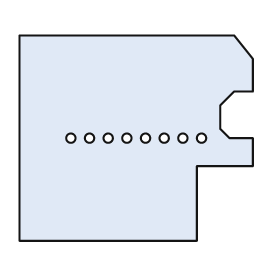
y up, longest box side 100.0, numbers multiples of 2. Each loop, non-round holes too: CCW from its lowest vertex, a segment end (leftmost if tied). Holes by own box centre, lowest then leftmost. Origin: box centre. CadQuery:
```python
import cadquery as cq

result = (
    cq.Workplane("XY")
    .moveTo(-50.0, -44.0)
    .lineTo(26.0, -44.0)
    .lineTo(26.0, -12.0)
    .lineTo(50.0, -12.0)
    .lineTo(50.0, 0.0)
    .lineTo(40.0, 0.0)
    .lineTo(36.0, 4.0)
    .lineTo(36.0, 14.0)
    .lineTo(42.0, 20.0)
    .lineTo(50.0, 20.0)
    .lineTo(50.0, 34.0)
    .lineTo(42.0, 44.0)
    .lineTo(-50.0, 44.0)
    .close()
    .moveTo(-28.0, 0.0)
    .circle(2.0)
    .moveTo(-20.0, 0.0)
    .circle(2.0)
    .moveTo(-12.0, 0.0)
    .circle(2.0)
    .moveTo(-4.0, 0.0)
    .circle(2.0)
    .moveTo(4.0, 0.0)
    .circle(2.0)
    .moveTo(12.0, 0.0)
    .circle(2.0)
    .moveTo(20.0, 0.0)
    .circle(2.0)
    .moveTo(28.0, 0.0)
    .circle(2.0)
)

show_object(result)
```